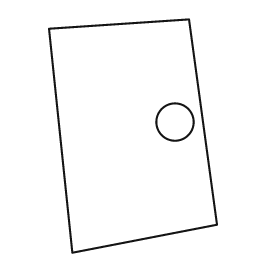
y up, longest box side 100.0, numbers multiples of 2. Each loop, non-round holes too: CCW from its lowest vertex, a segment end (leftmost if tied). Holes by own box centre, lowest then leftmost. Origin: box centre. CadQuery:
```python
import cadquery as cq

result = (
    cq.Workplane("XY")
    .moveTo(-26.0, -50.0)
    .lineTo(36.0, -38.0)
    .lineTo(24.0, 50.0)
    .lineTo(-36.0, 46.0)
    .close()
    .moveTo(18.0, 6.0)
    .circle(8.0)
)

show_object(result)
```